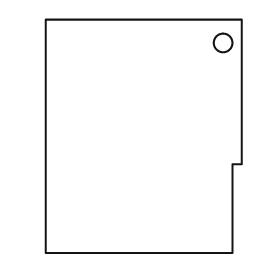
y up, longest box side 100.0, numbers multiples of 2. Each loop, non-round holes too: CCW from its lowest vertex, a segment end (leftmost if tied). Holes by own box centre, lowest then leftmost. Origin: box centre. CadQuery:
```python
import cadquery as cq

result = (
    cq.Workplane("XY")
    .moveTo(-42.0, -50.0)
    .lineTo(38.0, -50.0)
    .lineTo(38.0, -12.0)
    .lineTo(42.0, -12.0)
    .lineTo(42.0, 50.0)
    .lineTo(-42.0, 50.0)
    .close()
    .moveTo(34.0, 40.0)
    .circle(4.0)
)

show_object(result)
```